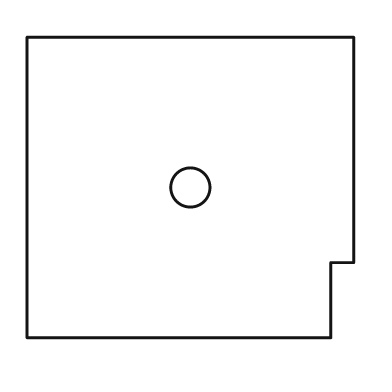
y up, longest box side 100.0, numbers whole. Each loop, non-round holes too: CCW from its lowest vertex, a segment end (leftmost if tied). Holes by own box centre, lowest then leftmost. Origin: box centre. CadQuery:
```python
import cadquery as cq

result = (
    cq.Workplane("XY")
    .moveTo(-50.0, -46.0)
    .lineTo(43.0, -46.0)
    .lineTo(43.0, -23.0)
    .lineTo(50.0, -23.0)
    .lineTo(50.0, 46.0)
    .lineTo(-50.0, 46.0)
    .close()
    .moveTo(0.0, 0.0)
    .circle(6.0)
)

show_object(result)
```